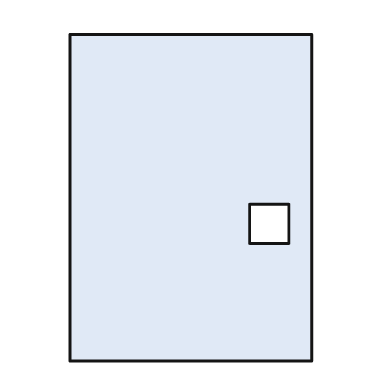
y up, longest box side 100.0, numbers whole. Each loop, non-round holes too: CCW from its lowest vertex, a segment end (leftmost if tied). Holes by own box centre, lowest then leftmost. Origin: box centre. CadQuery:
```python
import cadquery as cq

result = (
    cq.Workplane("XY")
    .moveTo(-37.0, -50.0)
    .lineTo(37.0, -50.0)
    .lineTo(37.0, 50.0)
    .lineTo(-37.0, 50.0)
    .close()
    .moveTo(18.0, -14.0)
    .lineTo(30.0, -14.0)
    .lineTo(30.0, -2.0)
    .lineTo(18.0, -2.0)
    .close()
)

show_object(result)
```